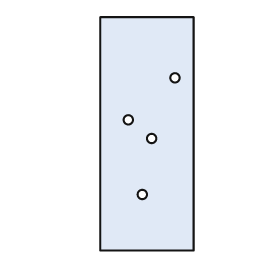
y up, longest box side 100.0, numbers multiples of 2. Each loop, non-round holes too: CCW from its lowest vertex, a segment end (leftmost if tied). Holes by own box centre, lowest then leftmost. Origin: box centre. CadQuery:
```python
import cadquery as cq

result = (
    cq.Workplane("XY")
    .moveTo(-20.0, -50.0)
    .lineTo(20.0, -50.0)
    .lineTo(20.0, 50.0)
    .lineTo(-20.0, 50.0)
    .close()
    .moveTo(-2.0, -26.0)
    .circle(2.0)
    .moveTo(2.0, -2.0)
    .circle(2.0)
    .moveTo(-8.0, 6.0)
    .circle(2.0)
    .moveTo(12.0, 24.0)
    .circle(2.0)
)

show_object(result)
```